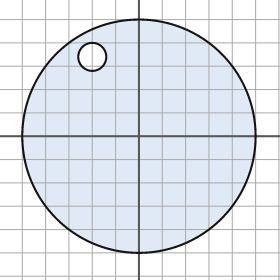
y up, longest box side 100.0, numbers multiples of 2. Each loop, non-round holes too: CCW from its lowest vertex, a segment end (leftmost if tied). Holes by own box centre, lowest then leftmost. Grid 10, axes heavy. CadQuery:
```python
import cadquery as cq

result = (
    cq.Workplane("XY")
    .moveTo(0.0, 0.0)
    .circle(50.0)
    .moveTo(-20.0, 34.0)
    .circle(6.0)
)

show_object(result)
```